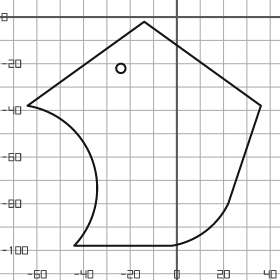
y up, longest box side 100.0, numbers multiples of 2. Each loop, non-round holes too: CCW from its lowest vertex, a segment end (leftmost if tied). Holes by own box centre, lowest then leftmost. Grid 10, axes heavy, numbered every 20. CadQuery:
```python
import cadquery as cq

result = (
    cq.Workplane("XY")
    .moveTo(-44.0, -98.0)
    .lineTo(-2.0, -98.0)
    .threePointArc((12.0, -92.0), (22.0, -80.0))
    .lineTo(36.0, -38.0)
    .lineTo(-14.0, -2.0)
    .lineTo(-64.0, -38.0)
    .threePointArc((-36.0, -62.0), (-44.0, -98.0))
    .close()
    .moveTo(-24.0, -22.0)
    .circle(2.0)
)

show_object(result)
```